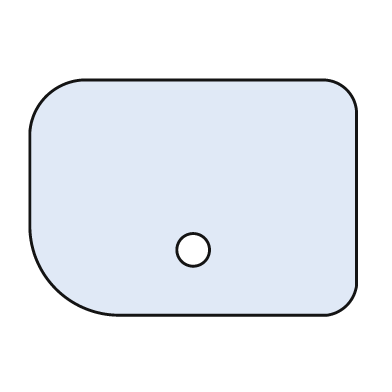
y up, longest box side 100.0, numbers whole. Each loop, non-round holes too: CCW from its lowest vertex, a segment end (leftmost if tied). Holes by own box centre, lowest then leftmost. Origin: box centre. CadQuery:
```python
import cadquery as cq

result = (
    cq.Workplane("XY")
    .moveTo(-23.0, -36.0)
    .lineTo(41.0, -36.0)
    .threePointArc((47.0, -33.0), (50.0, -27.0))
    .lineTo(50.0, 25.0)
    .threePointArc((47.0, 33.0), (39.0, 36.0))
    .lineTo(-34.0, 36.0)
    .threePointArc((-45.0, 31.0), (-50.0, 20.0))
    .lineTo(-50.0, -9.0)
    .threePointArc((-42.0, -28.0), (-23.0, -36.0))
    .close()
    .moveTo(0.0, -16.0)
    .circle(5.0)
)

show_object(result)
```